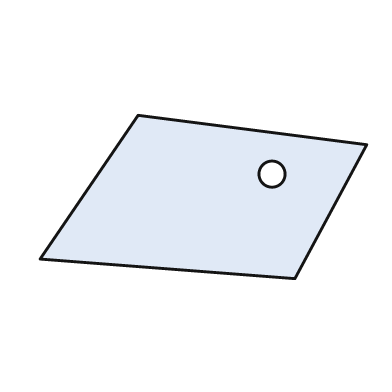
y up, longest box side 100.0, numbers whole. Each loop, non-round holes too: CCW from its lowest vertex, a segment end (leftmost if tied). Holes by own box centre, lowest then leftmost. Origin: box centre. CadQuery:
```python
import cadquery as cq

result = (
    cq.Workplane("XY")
    .moveTo(28.0, -25.0)
    .lineTo(50.0, 16.0)
    .lineTo(-20.0, 25.0)
    .lineTo(-50.0, -19.0)
    .close()
    .moveTo(21.0, 7.0)
    .circle(4.0)
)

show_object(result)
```